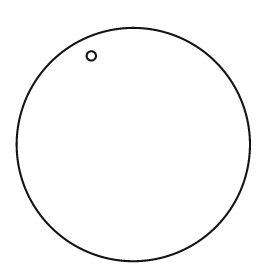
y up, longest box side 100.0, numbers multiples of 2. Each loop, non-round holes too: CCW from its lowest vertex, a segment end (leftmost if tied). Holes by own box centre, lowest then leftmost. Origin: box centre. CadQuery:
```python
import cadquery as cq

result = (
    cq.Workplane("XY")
    .moveTo(0.0, 0.0)
    .circle(50.0)
    .moveTo(-18.0, 38.0)
    .circle(2.0)
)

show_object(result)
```